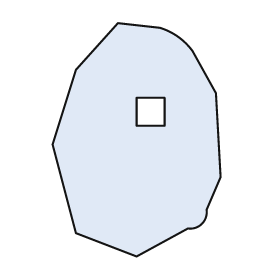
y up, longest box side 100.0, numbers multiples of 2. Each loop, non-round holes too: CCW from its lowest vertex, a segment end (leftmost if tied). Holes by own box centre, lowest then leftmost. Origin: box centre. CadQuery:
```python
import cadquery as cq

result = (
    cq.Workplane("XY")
    .moveTo(0.0, -50.0)
    .lineTo(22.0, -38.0)
    .threePointArc((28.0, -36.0), (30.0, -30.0))
    .lineTo(36.0, -16.0)
    .lineTo(34.0, 20.0)
    .lineTo(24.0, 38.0)
    .threePointArc((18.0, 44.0), (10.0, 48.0))
    .lineTo(-8.0, 50.0)
    .lineTo(-26.0, 30.0)
    .lineTo(-36.0, -2.0)
    .lineTo(-26.0, -40.0)
    .close()
    .moveTo(0.0, 6.0)
    .lineTo(12.0, 6.0)
    .lineTo(12.0, 18.0)
    .lineTo(0.0, 18.0)
    .close()
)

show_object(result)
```